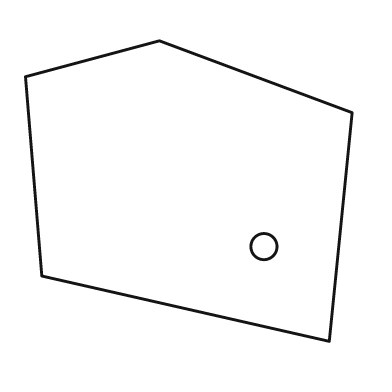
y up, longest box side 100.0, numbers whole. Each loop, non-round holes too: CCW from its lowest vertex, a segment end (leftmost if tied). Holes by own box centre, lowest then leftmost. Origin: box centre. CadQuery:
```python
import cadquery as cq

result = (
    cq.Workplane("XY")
    .moveTo(43.0, -46.0)
    .lineTo(50.0, 24.0)
    .lineTo(-9.0, 46.0)
    .lineTo(-50.0, 35.0)
    .lineTo(-45.0, -26.0)
    .close()
    .moveTo(23.0, -17.0)
    .circle(4.0)
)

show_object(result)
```